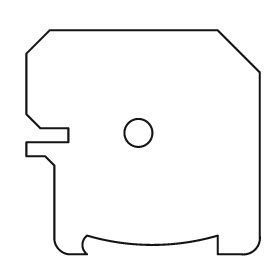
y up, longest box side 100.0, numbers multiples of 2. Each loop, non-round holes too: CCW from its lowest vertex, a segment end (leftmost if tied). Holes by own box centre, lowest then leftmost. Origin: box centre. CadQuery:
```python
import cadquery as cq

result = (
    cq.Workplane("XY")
    .moveTo(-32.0, -48.0)
    .lineTo(-24.0, -48.0)
    .threePointArc((-26.0, -44.0), (-24.0, -40.0))
    .threePointArc((4.0, -44.0), (32.0, -40.0))
    .lineTo(32.0, -48.0)
    .lineTo(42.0, -48.0)
    .threePointArc((48.0, -46.0), (50.0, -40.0))
    .lineTo(50.0, 30.0)
    .lineTo(32.0, 48.0)
    .lineTo(-40.0, 48.0)
    .lineTo(-50.0, 38.0)
    .lineTo(-50.0, 12.0)
    .lineTo(-44.0, 6.0)
    .lineTo(-32.0, 6.0)
    .lineTo(-32.0, 0.0)
    .lineTo(-50.0, 0.0)
    .lineTo(-50.0, -6.0)
    .lineTo(-42.0, -6.0)
    .lineTo(-38.0, -10.0)
    .lineTo(-38.0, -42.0)
    .threePointArc((-36.0, -46.0), (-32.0, -48.0))
    .close()
    .moveTo(-2.0, 4.0)
    .circle(6.0)
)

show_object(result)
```